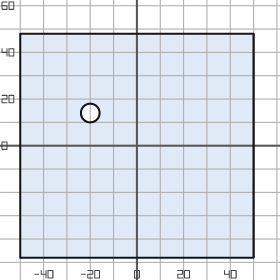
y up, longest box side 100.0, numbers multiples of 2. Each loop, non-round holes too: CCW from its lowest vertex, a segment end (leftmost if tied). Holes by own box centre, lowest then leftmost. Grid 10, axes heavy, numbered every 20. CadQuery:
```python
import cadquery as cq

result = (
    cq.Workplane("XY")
    .moveTo(-50.0, -48.0)
    .lineTo(50.0, -48.0)
    .lineTo(50.0, 48.0)
    .lineTo(-50.0, 48.0)
    .close()
    .moveTo(-20.0, 14.0)
    .circle(4.0)
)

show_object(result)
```